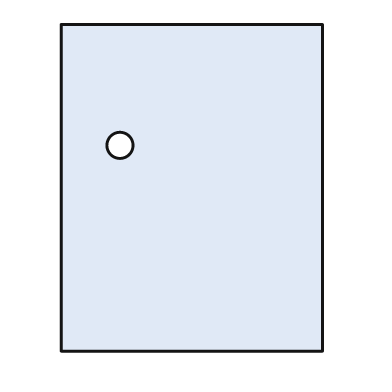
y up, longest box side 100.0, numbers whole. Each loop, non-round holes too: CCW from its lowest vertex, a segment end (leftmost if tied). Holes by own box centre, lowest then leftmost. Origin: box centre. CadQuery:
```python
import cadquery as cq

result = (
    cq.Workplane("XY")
    .moveTo(-40.0, -50.0)
    .lineTo(40.0, -50.0)
    .lineTo(40.0, 50.0)
    .lineTo(-40.0, 50.0)
    .close()
    .moveTo(-22.0, 13.0)
    .circle(4.0)
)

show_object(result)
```